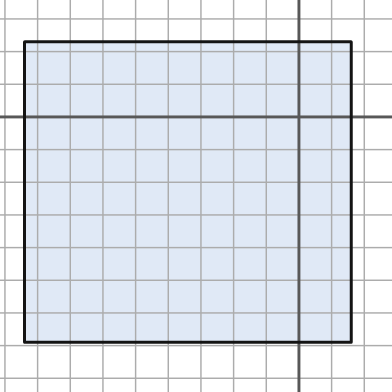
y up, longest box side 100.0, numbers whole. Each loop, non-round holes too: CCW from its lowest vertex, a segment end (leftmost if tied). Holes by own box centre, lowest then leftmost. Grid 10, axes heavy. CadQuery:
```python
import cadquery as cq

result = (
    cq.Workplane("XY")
    .moveTo(-84.0, -69.0)
    .lineTo(16.0, -69.0)
    .lineTo(16.0, 23.0)
    .lineTo(-84.0, 23.0)
    .close()
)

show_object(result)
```